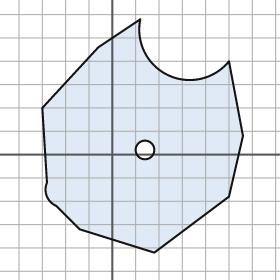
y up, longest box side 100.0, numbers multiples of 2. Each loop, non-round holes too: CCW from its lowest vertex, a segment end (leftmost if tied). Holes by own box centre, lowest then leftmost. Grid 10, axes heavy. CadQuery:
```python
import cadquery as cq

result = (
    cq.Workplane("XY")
    .moveTo(18.0, -42.0)
    .lineTo(50.0, -18.0)
    .lineTo(56.0, 8.0)
    .lineTo(50.0, 40.0)
    .threePointArc((24.0, 34.0), (12.0, 58.0))
    .lineTo(-6.0, 46.0)
    .lineTo(-30.0, 20.0)
    .lineTo(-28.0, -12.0)
    .threePointArc((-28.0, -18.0), (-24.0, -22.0))
    .lineTo(-14.0, -32.0)
    .close()
    .moveTo(14.0, 2.0)
    .circle(4.0)
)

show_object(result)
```